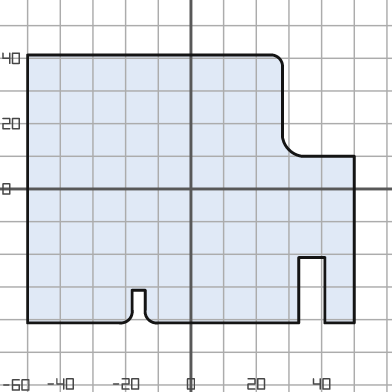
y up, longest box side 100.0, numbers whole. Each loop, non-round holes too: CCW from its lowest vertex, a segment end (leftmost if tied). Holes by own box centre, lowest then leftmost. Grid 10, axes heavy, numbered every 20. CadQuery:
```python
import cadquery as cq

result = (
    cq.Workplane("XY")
    .moveTo(-50.0, -41.0)
    .lineTo(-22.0, -41.0)
    .threePointArc((-19.0, -40.0), (-18.0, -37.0))
    .lineTo(-18.0, -31.0)
    .lineTo(-14.0, -31.0)
    .lineTo(-14.0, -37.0)
    .threePointArc((-13.0, -40.0), (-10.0, -41.0))
    .lineTo(33.0, -41.0)
    .lineTo(33.0, -21.0)
    .lineTo(41.0, -21.0)
    .lineTo(41.0, -41.0)
    .lineTo(50.0, -41.0)
    .lineTo(50.0, 10.0)
    .lineTo(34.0, 10.0)
    .threePointArc((30.0, 12.0), (28.0, 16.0))
    .lineTo(28.0, 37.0)
    .threePointArc((27.0, 40.0), (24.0, 41.0))
    .lineTo(-50.0, 41.0)
    .close()
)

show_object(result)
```